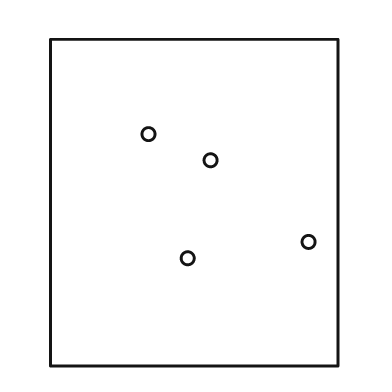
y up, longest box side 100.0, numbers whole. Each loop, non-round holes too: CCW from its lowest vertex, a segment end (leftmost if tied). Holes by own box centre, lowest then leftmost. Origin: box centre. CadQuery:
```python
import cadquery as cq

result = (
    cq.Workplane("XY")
    .moveTo(-44.0, -50.0)
    .lineTo(44.0, -50.0)
    .lineTo(44.0, 50.0)
    .lineTo(-44.0, 50.0)
    .close()
    .moveTo(-2.0, -17.0)
    .circle(2.0)
    .moveTo(35.0, -12.0)
    .circle(2.0)
    .moveTo(5.0, 13.0)
    .circle(2.0)
    .moveTo(-14.0, 21.0)
    .circle(2.0)
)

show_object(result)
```